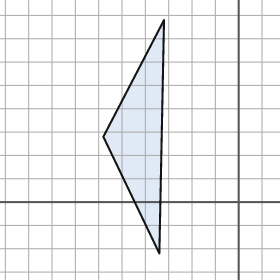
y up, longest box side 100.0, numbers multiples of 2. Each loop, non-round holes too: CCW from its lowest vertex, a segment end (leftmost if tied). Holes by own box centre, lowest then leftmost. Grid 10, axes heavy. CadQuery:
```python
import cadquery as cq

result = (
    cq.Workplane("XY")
    .moveTo(-34.0, -22.0)
    .lineTo(-32.0, 78.0)
    .lineTo(-58.0, 28.0)
    .close()
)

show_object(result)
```